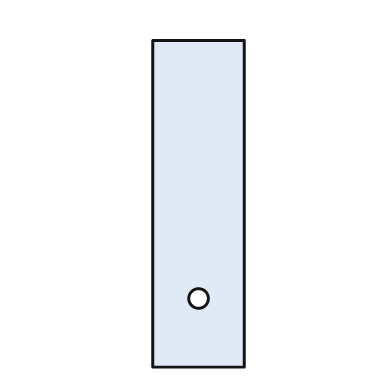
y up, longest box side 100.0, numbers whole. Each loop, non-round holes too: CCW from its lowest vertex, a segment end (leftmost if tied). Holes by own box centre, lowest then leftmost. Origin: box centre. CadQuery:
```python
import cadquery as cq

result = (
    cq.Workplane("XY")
    .moveTo(-14.0, -50.0)
    .lineTo(14.0, -50.0)
    .lineTo(14.0, 50.0)
    .lineTo(-14.0, 50.0)
    .close()
    .moveTo(0.0, -29.0)
    .circle(3.0)
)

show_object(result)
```